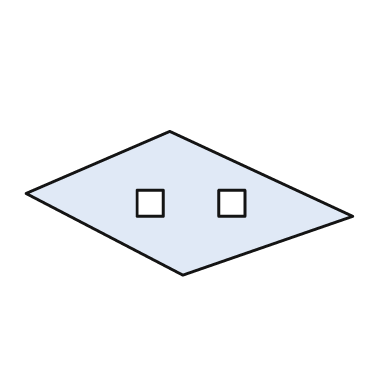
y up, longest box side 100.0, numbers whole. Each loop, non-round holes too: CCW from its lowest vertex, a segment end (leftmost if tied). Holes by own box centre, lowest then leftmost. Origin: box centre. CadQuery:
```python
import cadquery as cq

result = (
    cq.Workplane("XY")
    .moveTo(-2.0, -22.0)
    .lineTo(50.0, -4.0)
    .lineTo(-6.0, 22.0)
    .lineTo(-50.0, 3.0)
    .close()
    .moveTo(-16.0, -4.0)
    .lineTo(-8.0, -4.0)
    .lineTo(-8.0, 4.0)
    .lineTo(-16.0, 4.0)
    .close()
    .moveTo(9.0, -4.0)
    .lineTo(17.0, -4.0)
    .lineTo(17.0, 4.0)
    .lineTo(9.0, 4.0)
    .close()
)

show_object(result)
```